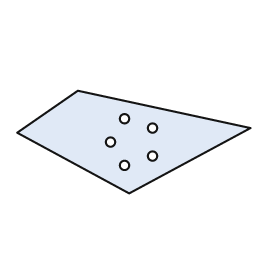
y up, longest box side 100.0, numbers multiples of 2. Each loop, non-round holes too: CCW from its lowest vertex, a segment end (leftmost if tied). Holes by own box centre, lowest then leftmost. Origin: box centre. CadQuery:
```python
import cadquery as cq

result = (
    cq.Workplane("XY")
    .moveTo(-2.0, -22.0)
    .lineTo(50.0, 6.0)
    .lineTo(-24.0, 22.0)
    .lineTo(-50.0, 4.0)
    .close()
    .moveTo(-4.0, -10.0)
    .circle(2.0)
    .moveTo(8.0, -6.0)
    .circle(2.0)
    .moveTo(-10.0, 0.0)
    .circle(2.0)
    .moveTo(8.0, 6.0)
    .circle(2.0)
    .moveTo(-4.0, 10.0)
    .circle(2.0)
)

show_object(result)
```